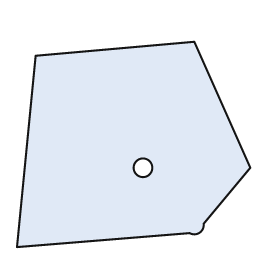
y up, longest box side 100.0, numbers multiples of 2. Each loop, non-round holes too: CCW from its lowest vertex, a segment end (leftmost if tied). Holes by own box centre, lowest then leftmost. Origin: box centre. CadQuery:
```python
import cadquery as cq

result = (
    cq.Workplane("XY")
    .moveTo(-50.0, -44.0)
    .lineTo(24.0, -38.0)
    .threePointArc((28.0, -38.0), (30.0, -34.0))
    .lineTo(50.0, -10.0)
    .lineTo(26.0, 44.0)
    .lineTo(-42.0, 38.0)
    .close()
    .moveTo(4.0, -10.0)
    .circle(4.0)
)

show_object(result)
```